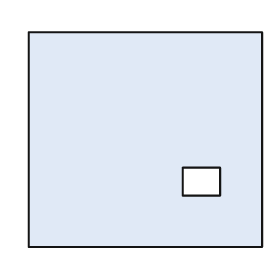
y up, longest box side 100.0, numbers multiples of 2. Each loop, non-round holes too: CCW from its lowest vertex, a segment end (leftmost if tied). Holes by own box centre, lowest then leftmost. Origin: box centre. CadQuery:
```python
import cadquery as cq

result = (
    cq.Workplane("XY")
    .moveTo(-50.0, -46.0)
    .lineTo(50.0, -46.0)
    .lineTo(50.0, 46.0)
    .lineTo(-50.0, 46.0)
    .close()
    .moveTo(16.0, -24.0)
    .lineTo(32.0, -24.0)
    .lineTo(32.0, -12.0)
    .lineTo(16.0, -12.0)
    .close()
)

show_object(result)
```